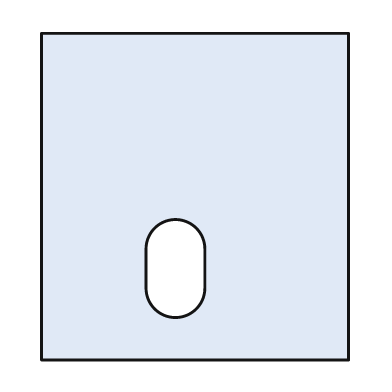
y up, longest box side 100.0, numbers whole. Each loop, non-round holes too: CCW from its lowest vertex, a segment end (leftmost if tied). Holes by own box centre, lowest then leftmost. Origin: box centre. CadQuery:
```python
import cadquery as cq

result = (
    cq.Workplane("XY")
    .moveTo(-47.0, -50.0)
    .lineTo(47.0, -50.0)
    .lineTo(47.0, 50.0)
    .lineTo(-47.0, 50.0)
    .close()
    .moveTo(-15.0, -28.0)
    .threePointArc((-6.0, -37.0), (3.0, -28.0))
    .lineTo(3.0, -16.0)
    .threePointArc((-6.0, -7.0), (-15.0, -16.0))
    .close()
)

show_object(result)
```